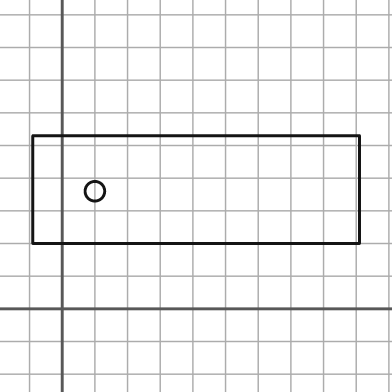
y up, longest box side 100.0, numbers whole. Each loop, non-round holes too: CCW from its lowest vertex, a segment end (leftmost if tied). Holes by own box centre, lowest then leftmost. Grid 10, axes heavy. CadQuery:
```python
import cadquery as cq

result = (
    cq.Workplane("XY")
    .moveTo(-9.0, 20.0)
    .lineTo(91.0, 20.0)
    .lineTo(91.0, 53.0)
    .lineTo(-9.0, 53.0)
    .close()
    .moveTo(10.0, 36.0)
    .circle(3.0)
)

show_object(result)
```